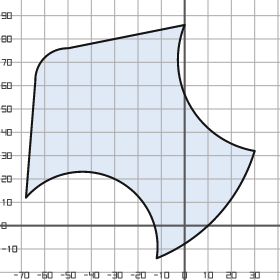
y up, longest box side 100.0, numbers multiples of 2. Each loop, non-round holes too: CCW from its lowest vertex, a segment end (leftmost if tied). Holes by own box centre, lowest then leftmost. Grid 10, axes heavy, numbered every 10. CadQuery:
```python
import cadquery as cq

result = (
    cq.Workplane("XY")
    .moveTo(-12.0, -14.0)
    .threePointArc((14.0, 4.0), (30.0, 32.0))
    .threePointArc((2.0, 52.0), (0.0, 86.0))
    .lineTo(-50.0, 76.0)
    .threePointArc((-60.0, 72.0), (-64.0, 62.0))
    .lineTo(-68.0, 12.0)
    .threePointArc((-30.0, 20.0), (-12.0, -14.0))
    .close()
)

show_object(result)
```